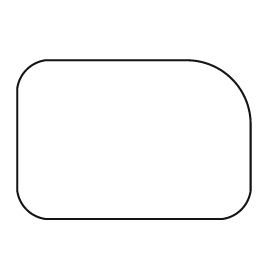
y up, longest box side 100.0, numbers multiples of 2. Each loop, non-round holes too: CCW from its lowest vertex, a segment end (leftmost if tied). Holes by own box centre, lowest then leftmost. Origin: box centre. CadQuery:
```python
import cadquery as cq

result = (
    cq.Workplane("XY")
    .moveTo(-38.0, -34.0)
    .lineTo(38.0, -34.0)
    .threePointArc((46.0, -30.0), (50.0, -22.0))
    .lineTo(50.0, 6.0)
    .threePointArc((42.0, 26.0), (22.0, 34.0))
    .lineTo(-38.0, 34.0)
    .threePointArc((-46.0, 30.0), (-50.0, 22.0))
    .lineTo(-50.0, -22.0)
    .threePointArc((-46.0, -30.0), (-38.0, -34.0))
    .close()
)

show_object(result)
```